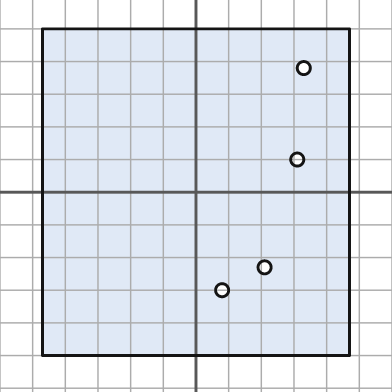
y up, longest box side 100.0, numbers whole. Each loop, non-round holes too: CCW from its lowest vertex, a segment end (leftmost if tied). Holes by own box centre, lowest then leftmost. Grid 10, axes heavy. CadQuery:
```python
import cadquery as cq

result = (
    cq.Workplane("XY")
    .moveTo(-47.0, -50.0)
    .lineTo(47.0, -50.0)
    .lineTo(47.0, 50.0)
    .lineTo(-47.0, 50.0)
    .close()
    .moveTo(8.0, -30.0)
    .circle(2.0)
    .moveTo(21.0, -23.0)
    .circle(2.0)
    .moveTo(31.0, 10.0)
    .circle(2.0)
    .moveTo(33.0, 38.0)
    .circle(2.0)
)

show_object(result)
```